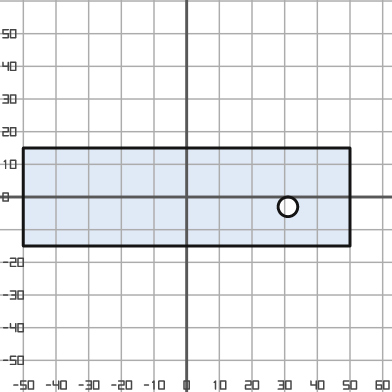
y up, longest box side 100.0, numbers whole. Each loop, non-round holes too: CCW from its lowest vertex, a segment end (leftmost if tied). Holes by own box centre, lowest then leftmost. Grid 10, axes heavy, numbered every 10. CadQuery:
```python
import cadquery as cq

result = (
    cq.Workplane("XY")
    .moveTo(-50.0, -15.0)
    .lineTo(50.0, -15.0)
    .lineTo(50.0, 15.0)
    .lineTo(-50.0, 15.0)
    .close()
    .moveTo(31.0, -3.0)
    .circle(3.0)
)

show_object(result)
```